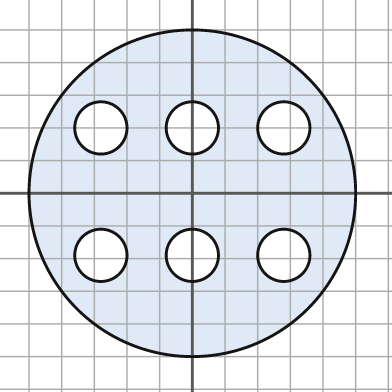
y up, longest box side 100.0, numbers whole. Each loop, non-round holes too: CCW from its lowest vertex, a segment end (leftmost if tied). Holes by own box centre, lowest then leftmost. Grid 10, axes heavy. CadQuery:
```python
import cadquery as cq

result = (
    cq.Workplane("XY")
    .moveTo(0.0, 0.0)
    .circle(50.0)
    .moveTo(-28.0, -19.0)
    .circle(8.0)
    .moveTo(0.0, -19.0)
    .circle(8.0)
    .moveTo(28.0, -19.0)
    .circle(8.0)
    .moveTo(-28.0, 20.0)
    .circle(8.0)
    .moveTo(0.0, 20.0)
    .circle(8.0)
    .moveTo(28.0, 20.0)
    .circle(8.0)
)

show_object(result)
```